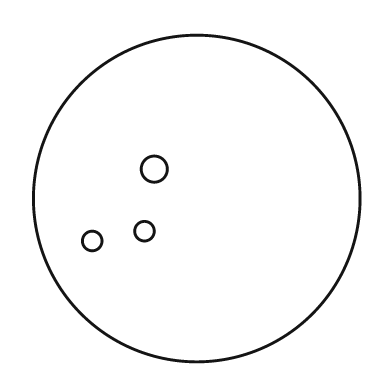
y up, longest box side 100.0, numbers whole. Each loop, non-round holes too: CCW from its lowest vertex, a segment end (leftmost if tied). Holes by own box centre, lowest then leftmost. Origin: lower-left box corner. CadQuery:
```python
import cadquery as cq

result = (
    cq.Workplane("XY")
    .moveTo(50.0, 50.0)
    .circle(50.0)
    .moveTo(18.0, 37.0)
    .circle(3.0)
    .moveTo(34.0, 40.0)
    .circle(3.0)
    .moveTo(37.0, 59.0)
    .circle(4.0)
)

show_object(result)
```